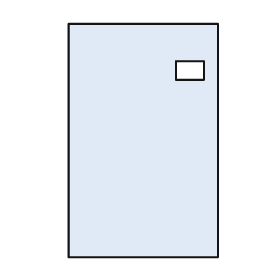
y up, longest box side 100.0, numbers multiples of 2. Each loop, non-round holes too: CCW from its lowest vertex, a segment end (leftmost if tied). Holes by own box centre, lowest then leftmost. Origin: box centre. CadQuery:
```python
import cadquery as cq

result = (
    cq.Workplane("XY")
    .moveTo(-32.0, -50.0)
    .lineTo(32.0, -50.0)
    .lineTo(32.0, 50.0)
    .lineTo(-32.0, 50.0)
    .close()
    .moveTo(14.0, 26.0)
    .lineTo(26.0, 26.0)
    .lineTo(26.0, 34.0)
    .lineTo(14.0, 34.0)
    .close()
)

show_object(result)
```